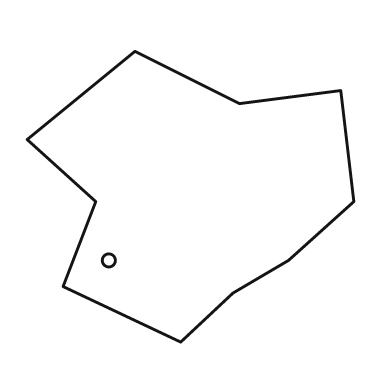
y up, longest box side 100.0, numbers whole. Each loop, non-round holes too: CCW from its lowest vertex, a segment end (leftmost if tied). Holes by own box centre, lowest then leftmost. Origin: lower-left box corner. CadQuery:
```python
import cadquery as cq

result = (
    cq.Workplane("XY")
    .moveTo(47.0, 0.0)
    .lineTo(63.0, 15.0)
    .lineTo(80.0, 25.0)
    .lineTo(100.0, 43.0)
    .lineTo(96.0, 77.0)
    .lineTo(65.0, 73.0)
    .lineTo(33.0, 89.0)
    .lineTo(0.0, 62.0)
    .lineTo(21.0, 43.0)
    .lineTo(11.0, 17.0)
    .close()
    .moveTo(25.0, 25.0)
    .circle(2.0)
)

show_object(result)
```